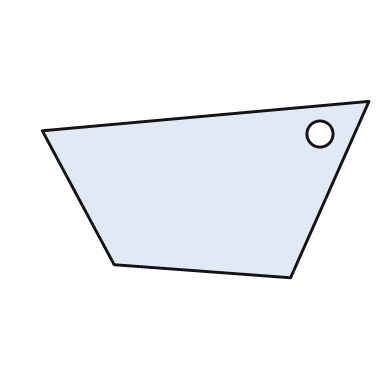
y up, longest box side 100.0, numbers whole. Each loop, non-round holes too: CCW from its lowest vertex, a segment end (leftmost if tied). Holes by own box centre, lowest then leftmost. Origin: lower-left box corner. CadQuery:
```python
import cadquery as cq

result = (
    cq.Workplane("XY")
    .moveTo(76.0, 0.0)
    .lineTo(100.0, 54.0)
    .lineTo(0.0, 45.0)
    .lineTo(22.0, 4.0)
    .close()
    .moveTo(85.0, 44.0)
    .circle(4.0)
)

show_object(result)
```